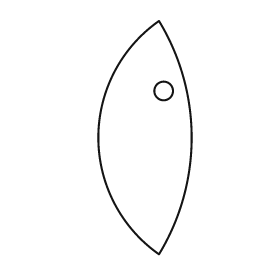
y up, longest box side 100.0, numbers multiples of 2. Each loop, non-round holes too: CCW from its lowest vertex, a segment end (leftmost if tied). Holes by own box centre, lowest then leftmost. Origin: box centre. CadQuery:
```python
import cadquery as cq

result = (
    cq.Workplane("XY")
    .moveTo(6.0, -50.0)
    .threePointArc((20.0, 0.0), (6.0, 50.0))
    .threePointArc((-20.0, 0.0), (6.0, -50.0))
    .close()
    .moveTo(8.0, 20.0)
    .circle(4.0)
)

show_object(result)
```